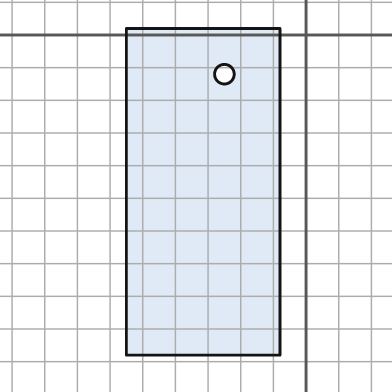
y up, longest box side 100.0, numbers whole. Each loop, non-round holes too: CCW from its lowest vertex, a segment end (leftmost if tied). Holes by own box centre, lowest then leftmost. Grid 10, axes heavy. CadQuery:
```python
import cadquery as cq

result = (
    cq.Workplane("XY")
    .moveTo(-55.0, -98.0)
    .lineTo(-8.0, -98.0)
    .lineTo(-8.0, 2.0)
    .lineTo(-55.0, 2.0)
    .close()
    .moveTo(-25.0, -12.0)
    .circle(3.0)
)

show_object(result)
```